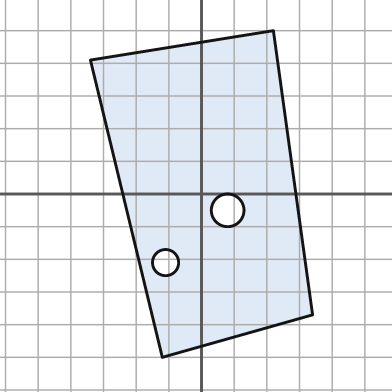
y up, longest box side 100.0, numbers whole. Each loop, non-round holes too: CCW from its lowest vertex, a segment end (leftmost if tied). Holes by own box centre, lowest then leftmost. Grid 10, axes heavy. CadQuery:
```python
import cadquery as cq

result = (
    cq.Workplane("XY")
    .moveTo(-12.0, -50.0)
    .lineTo(34.0, -37.0)
    .lineTo(22.0, 50.0)
    .lineTo(-34.0, 41.0)
    .close()
    .moveTo(-11.0, -21.0)
    .circle(4.0)
    .moveTo(8.0, -5.0)
    .circle(5.0)
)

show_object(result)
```